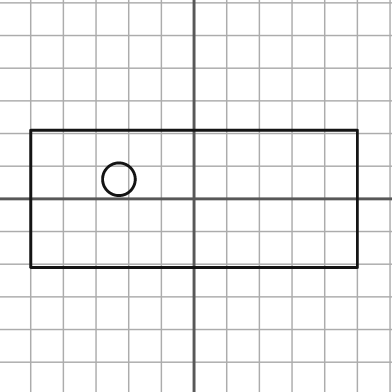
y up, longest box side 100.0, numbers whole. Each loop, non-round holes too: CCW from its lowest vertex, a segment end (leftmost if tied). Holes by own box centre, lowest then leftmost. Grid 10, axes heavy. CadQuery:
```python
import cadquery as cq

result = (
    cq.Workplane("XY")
    .moveTo(-50.0, -21.0)
    .lineTo(50.0, -21.0)
    .lineTo(50.0, 21.0)
    .lineTo(-50.0, 21.0)
    .close()
    .moveTo(-23.0, 6.0)
    .circle(5.0)
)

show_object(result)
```